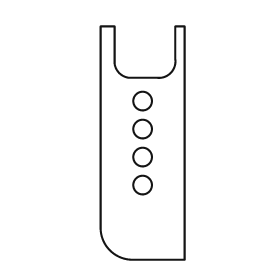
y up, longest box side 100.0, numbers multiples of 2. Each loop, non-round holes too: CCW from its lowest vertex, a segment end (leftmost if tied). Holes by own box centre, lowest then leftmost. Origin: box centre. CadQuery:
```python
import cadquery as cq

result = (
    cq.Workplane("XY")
    .moveTo(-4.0, -50.0)
    .lineTo(18.0, -50.0)
    .lineTo(18.0, 50.0)
    .lineTo(14.0, 50.0)
    .lineTo(14.0, 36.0)
    .threePointArc((12.0, 30.0), (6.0, 28.0))
    .lineTo(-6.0, 28.0)
    .threePointArc((-10.0, 30.0), (-12.0, 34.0))
    .lineTo(-12.0, 50.0)
    .lineTo(-18.0, 50.0)
    .lineTo(-18.0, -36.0)
    .threePointArc((-14.0, -46.0), (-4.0, -50.0))
    .close()
    .moveTo(0.0, -18.0)
    .circle(4.0)
    .moveTo(0.0, -6.0)
    .circle(4.0)
    .moveTo(0.0, 6.0)
    .circle(4.0)
    .moveTo(0.0, 18.0)
    .circle(4.0)
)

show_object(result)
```